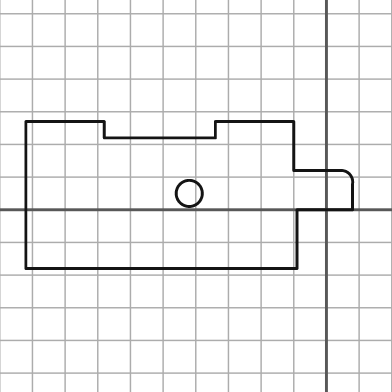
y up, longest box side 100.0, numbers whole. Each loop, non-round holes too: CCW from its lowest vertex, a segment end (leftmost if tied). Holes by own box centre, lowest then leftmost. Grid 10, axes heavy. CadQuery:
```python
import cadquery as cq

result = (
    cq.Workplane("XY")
    .moveTo(-92.0, -18.0)
    .lineTo(-9.0, -18.0)
    .lineTo(-9.0, 0.0)
    .lineTo(8.0, 0.0)
    .lineTo(8.0, 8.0)
    .threePointArc((7.0, 11.0), (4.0, 12.0))
    .lineTo(-10.0, 12.0)
    .lineTo(-10.0, 27.0)
    .lineTo(-34.0, 27.0)
    .lineTo(-34.0, 22.0)
    .lineTo(-68.0, 22.0)
    .lineTo(-68.0, 27.0)
    .lineTo(-92.0, 27.0)
    .close()
    .moveTo(-42.0, 5.0)
    .circle(4.0)
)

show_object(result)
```